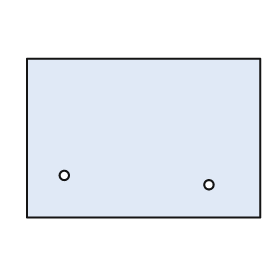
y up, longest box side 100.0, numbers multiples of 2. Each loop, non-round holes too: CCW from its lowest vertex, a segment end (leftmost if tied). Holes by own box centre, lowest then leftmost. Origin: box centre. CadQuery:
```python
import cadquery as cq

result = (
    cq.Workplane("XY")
    .moveTo(-50.0, -34.0)
    .lineTo(50.0, -34.0)
    .lineTo(50.0, 34.0)
    .lineTo(-50.0, 34.0)
    .close()
    .moveTo(28.0, -20.0)
    .circle(2.0)
    .moveTo(-34.0, -16.0)
    .circle(2.0)
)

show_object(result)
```